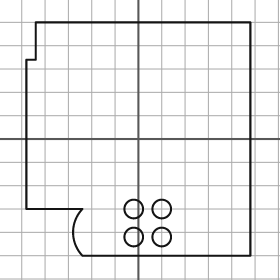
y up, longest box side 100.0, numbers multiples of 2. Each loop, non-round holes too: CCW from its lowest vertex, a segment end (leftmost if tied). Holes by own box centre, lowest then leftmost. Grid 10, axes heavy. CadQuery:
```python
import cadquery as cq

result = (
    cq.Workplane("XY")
    .moveTo(-24.0, -50.0)
    .lineTo(48.0, -50.0)
    .lineTo(48.0, 50.0)
    .lineTo(-44.0, 50.0)
    .lineTo(-44.0, 34.0)
    .lineTo(-48.0, 34.0)
    .lineTo(-48.0, -30.0)
    .lineTo(-24.0, -30.0)
    .threePointArc((-28.0, -40.0), (-24.0, -50.0))
    .close()
    .moveTo(-2.0, -42.0)
    .circle(4.0)
    .moveTo(10.0, -42.0)
    .circle(4.0)
    .moveTo(-2.0, -30.0)
    .circle(4.0)
    .moveTo(10.0, -30.0)
    .circle(4.0)
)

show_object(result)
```